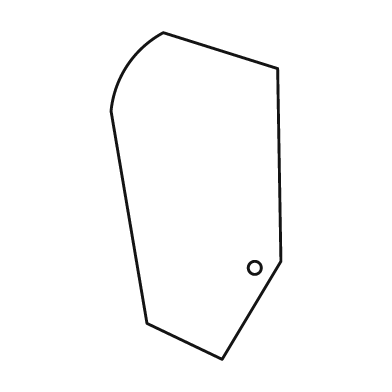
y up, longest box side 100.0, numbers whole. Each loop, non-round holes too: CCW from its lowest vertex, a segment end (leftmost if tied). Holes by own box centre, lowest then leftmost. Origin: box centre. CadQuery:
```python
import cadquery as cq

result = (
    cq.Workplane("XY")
    .moveTo(8.0, -50.0)
    .lineTo(26.0, -20.0)
    .lineTo(25.0, 39.0)
    .lineTo(-10.0, 50.0)
    .threePointArc((-21.0, 40.0), (-26.0, 26.0))
    .lineTo(-15.0, -39.0)
    .close()
    .moveTo(18.0, -22.0)
    .circle(2.0)
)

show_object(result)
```